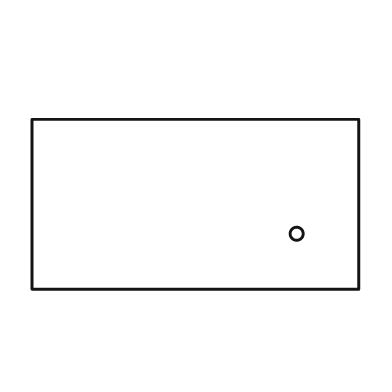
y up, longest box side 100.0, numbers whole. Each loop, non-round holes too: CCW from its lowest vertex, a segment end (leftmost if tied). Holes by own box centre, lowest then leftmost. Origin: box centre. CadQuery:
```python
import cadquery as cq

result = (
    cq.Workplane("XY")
    .moveTo(-50.0, -26.0)
    .lineTo(50.0, -26.0)
    .lineTo(50.0, 26.0)
    .lineTo(-50.0, 26.0)
    .close()
    .moveTo(31.0, -9.0)
    .circle(2.0)
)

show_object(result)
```